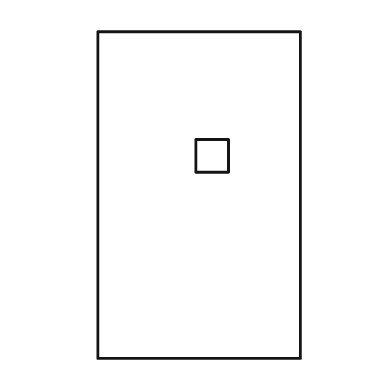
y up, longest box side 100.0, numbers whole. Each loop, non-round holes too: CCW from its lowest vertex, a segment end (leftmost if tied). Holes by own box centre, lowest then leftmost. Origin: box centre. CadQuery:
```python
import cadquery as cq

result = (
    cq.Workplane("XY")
    .moveTo(-31.0, -50.0)
    .lineTo(31.0, -50.0)
    .lineTo(31.0, 50.0)
    .lineTo(-31.0, 50.0)
    .close()
    .moveTo(-1.0, 7.0)
    .lineTo(9.0, 7.0)
    .lineTo(9.0, 17.0)
    .lineTo(-1.0, 17.0)
    .close()
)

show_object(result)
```